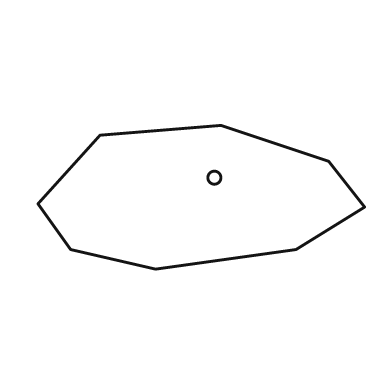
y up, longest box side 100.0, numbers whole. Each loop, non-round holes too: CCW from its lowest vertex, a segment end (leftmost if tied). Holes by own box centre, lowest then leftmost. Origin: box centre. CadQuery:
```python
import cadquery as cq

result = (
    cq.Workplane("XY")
    .moveTo(-14.0, -22.0)
    .lineTo(29.0, -16.0)
    .lineTo(50.0, -3.0)
    .lineTo(39.0, 11.0)
    .lineTo(6.0, 22.0)
    .lineTo(-31.0, 19.0)
    .lineTo(-50.0, -2.0)
    .lineTo(-40.0, -16.0)
    .close()
    .moveTo(4.0, 6.0)
    .circle(2.0)
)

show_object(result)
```